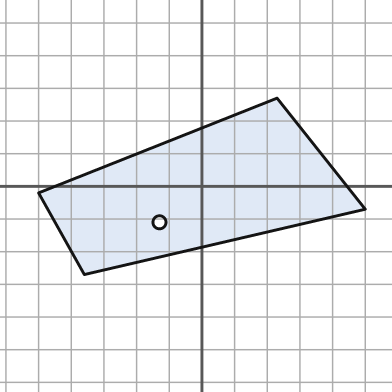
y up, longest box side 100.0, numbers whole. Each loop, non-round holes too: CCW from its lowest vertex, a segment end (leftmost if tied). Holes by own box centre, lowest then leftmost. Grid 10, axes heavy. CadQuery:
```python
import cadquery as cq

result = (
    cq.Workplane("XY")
    .moveTo(-36.0, -27.0)
    .lineTo(50.0, -7.0)
    .lineTo(23.0, 27.0)
    .lineTo(-50.0, -2.0)
    .close()
    .moveTo(-13.0, -11.0)
    .circle(2.0)
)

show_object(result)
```